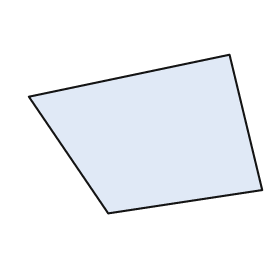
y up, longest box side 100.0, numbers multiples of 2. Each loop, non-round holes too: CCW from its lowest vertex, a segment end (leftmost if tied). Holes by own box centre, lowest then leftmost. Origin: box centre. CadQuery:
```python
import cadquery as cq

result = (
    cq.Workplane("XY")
    .moveTo(-16.0, -34.0)
    .lineTo(50.0, -24.0)
    .lineTo(36.0, 34.0)
    .lineTo(-50.0, 16.0)
    .close()
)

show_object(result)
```